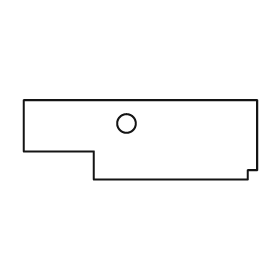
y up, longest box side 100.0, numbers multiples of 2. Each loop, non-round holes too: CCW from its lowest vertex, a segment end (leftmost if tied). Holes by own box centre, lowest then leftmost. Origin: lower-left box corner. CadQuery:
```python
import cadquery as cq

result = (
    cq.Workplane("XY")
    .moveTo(30.0, 0.0)
    .lineTo(96.0, 0.0)
    .lineTo(96.0, 4.0)
    .lineTo(100.0, 4.0)
    .lineTo(100.0, 34.0)
    .lineTo(0.0, 34.0)
    .lineTo(0.0, 12.0)
    .lineTo(30.0, 12.0)
    .close()
    .moveTo(44.0, 24.0)
    .circle(4.0)
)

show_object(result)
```